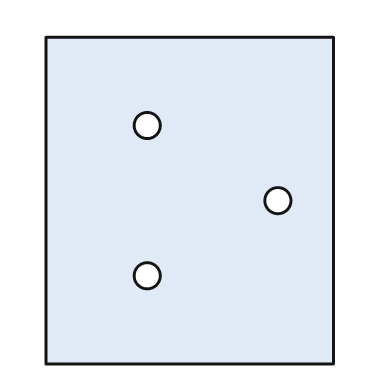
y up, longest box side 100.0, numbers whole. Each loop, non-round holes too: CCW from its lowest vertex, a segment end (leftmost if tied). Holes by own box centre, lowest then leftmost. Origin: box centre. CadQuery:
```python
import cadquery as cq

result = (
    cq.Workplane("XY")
    .moveTo(-44.0, -50.0)
    .lineTo(44.0, -50.0)
    .lineTo(44.0, 50.0)
    .lineTo(-44.0, 50.0)
    .close()
    .moveTo(-13.0, -23.0)
    .circle(4.0)
    .moveTo(27.0, 0.0)
    .circle(4.0)
    .moveTo(-13.0, 23.0)
    .circle(4.0)
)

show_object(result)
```